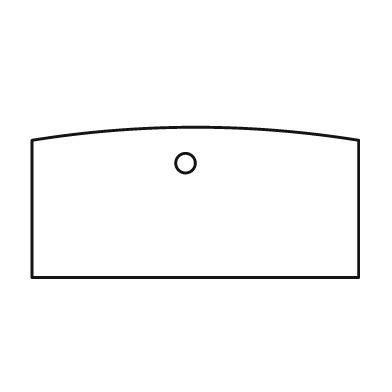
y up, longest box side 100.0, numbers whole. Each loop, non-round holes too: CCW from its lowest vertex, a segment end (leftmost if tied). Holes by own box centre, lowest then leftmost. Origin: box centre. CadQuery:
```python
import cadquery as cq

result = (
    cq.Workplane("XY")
    .moveTo(-50.0, -23.0)
    .lineTo(50.0, -23.0)
    .lineTo(50.0, 19.0)
    .threePointArc((0.0, 23.0), (-50.0, 19.0))
    .close()
    .moveTo(-3.0, 12.0)
    .circle(3.0)
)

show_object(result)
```